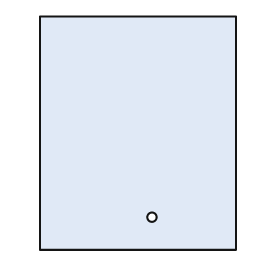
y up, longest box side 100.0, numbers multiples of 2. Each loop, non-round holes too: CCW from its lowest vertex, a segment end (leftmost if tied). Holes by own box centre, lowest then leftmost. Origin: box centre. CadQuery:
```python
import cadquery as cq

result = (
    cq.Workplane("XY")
    .moveTo(-42.0, -50.0)
    .lineTo(42.0, -50.0)
    .lineTo(42.0, 50.0)
    .lineTo(-42.0, 50.0)
    .close()
    .moveTo(6.0, -36.0)
    .circle(2.0)
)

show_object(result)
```